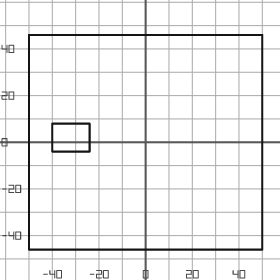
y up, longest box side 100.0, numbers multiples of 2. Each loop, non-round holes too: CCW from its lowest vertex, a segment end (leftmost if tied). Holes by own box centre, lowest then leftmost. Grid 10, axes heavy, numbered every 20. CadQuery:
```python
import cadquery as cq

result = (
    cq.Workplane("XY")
    .moveTo(-50.0, -46.0)
    .lineTo(50.0, -46.0)
    .lineTo(50.0, 46.0)
    .lineTo(-50.0, 46.0)
    .close()
    .moveTo(-40.0, -4.0)
    .lineTo(-24.0, -4.0)
    .lineTo(-24.0, 8.0)
    .lineTo(-40.0, 8.0)
    .close()
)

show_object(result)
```